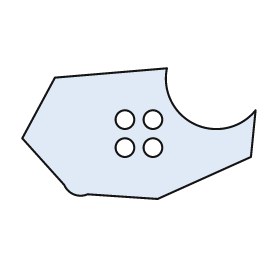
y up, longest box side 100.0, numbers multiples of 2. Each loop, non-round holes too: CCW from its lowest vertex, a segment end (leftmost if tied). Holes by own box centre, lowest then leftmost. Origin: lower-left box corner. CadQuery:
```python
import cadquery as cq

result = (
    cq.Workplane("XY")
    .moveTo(58.0, 0.0)
    .lineTo(98.0, 18.0)
    .lineTo(100.0, 38.0)
    .threePointArc((74.0, 32.0), (62.0, 56.0))
    .lineTo(14.0, 52.0)
    .lineTo(0.0, 26.0)
    .lineTo(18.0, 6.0)
    .threePointArc((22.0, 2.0), (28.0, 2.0))
    .close()
    .moveTo(44.0, 22.0)
    .circle(4.0)
    .moveTo(56.0, 22.0)
    .circle(4.0)
    .moveTo(44.0, 34.0)
    .circle(4.0)
    .moveTo(56.0, 34.0)
    .circle(4.0)
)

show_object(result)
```